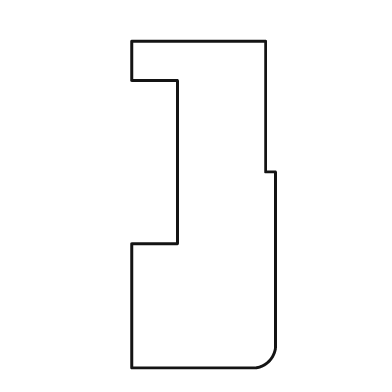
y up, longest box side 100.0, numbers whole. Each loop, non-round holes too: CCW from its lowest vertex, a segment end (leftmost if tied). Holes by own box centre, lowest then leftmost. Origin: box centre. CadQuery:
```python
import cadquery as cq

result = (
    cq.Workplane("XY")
    .moveTo(-22.0, -50.0)
    .lineTo(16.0, -50.0)
    .threePointArc((20.0, -48.0), (22.0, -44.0))
    .lineTo(22.0, 10.0)
    .lineTo(19.0, 10.0)
    .lineTo(19.0, 50.0)
    .lineTo(-22.0, 50.0)
    .lineTo(-22.0, 38.0)
    .lineTo(-8.0, 38.0)
    .lineTo(-8.0, -12.0)
    .lineTo(-22.0, -12.0)
    .close()
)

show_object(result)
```